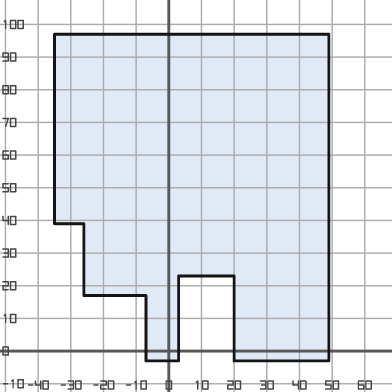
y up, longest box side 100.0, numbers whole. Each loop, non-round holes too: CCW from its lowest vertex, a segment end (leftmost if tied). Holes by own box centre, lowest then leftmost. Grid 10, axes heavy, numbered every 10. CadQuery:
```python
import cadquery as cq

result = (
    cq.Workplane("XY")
    .moveTo(-7.0, -3.0)
    .lineTo(3.0, -3.0)
    .lineTo(3.0, 23.0)
    .lineTo(20.0, 23.0)
    .lineTo(20.0, -3.0)
    .lineTo(49.0, -3.0)
    .lineTo(49.0, 97.0)
    .lineTo(-35.0, 97.0)
    .lineTo(-35.0, 39.0)
    .lineTo(-26.0, 39.0)
    .lineTo(-26.0, 17.0)
    .lineTo(-7.0, 17.0)
    .close()
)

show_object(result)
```